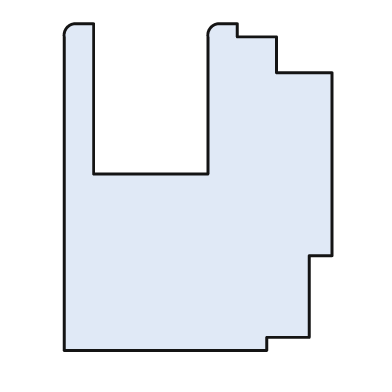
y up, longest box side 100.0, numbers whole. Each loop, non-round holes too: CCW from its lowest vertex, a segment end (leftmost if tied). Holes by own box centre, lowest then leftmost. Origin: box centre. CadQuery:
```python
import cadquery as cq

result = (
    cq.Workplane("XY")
    .moveTo(-41.0, -50.0)
    .lineTo(21.0, -50.0)
    .lineTo(21.0, -46.0)
    .lineTo(34.0, -46.0)
    .lineTo(34.0, -21.0)
    .lineTo(41.0, -21.0)
    .lineTo(41.0, 35.0)
    .lineTo(24.0, 35.0)
    .lineTo(24.0, 46.0)
    .lineTo(12.0, 46.0)
    .lineTo(12.0, 50.0)
    .lineTo(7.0, 50.0)
    .threePointArc((4.0, 49.0), (3.0, 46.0))
    .lineTo(3.0, 4.0)
    .lineTo(-32.0, 4.0)
    .lineTo(-32.0, 50.0)
    .lineTo(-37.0, 50.0)
    .threePointArc((-40.0, 49.0), (-41.0, 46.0))
    .close()
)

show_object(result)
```